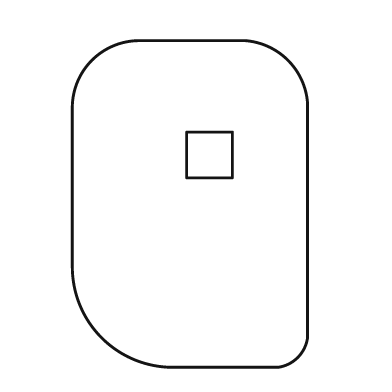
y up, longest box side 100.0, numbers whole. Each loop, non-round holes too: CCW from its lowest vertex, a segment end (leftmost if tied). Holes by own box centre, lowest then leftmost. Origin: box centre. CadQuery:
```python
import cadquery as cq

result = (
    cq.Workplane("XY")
    .moveTo(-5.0, -50.0)
    .lineTo(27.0, -50.0)
    .threePointArc((33.0, -47.0), (36.0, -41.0))
    .lineTo(36.0, 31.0)
    .threePointArc((30.0, 44.0), (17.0, 50.0))
    .lineTo(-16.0, 50.0)
    .threePointArc((-30.0, 44.0), (-36.0, 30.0))
    .lineTo(-36.0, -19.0)
    .threePointArc((-27.0, -41.0), (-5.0, -50.0))
    .close()
    .moveTo(-1.0, 8.0)
    .lineTo(13.0, 8.0)
    .lineTo(13.0, 22.0)
    .lineTo(-1.0, 22.0)
    .close()
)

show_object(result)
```